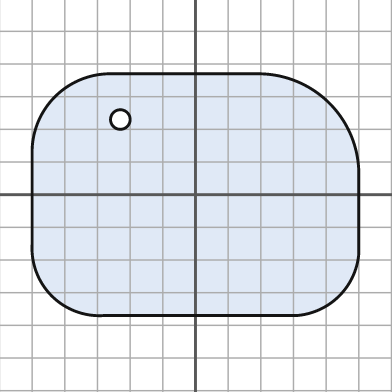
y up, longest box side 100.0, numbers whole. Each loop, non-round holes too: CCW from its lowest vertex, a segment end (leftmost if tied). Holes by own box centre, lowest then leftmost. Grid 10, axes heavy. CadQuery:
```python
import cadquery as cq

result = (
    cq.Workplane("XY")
    .moveTo(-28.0, -37.0)
    .lineTo(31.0, -37.0)
    .threePointArc((44.0, -31.0), (50.0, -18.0))
    .lineTo(50.0, 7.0)
    .threePointArc((41.0, 28.0), (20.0, 37.0))
    .lineTo(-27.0, 37.0)
    .threePointArc((-43.0, 30.0), (-50.0, 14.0))
    .lineTo(-50.0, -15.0)
    .threePointArc((-44.0, -31.0), (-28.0, -37.0))
    .close()
    .moveTo(-23.0, 23.0)
    .circle(3.0)
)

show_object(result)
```